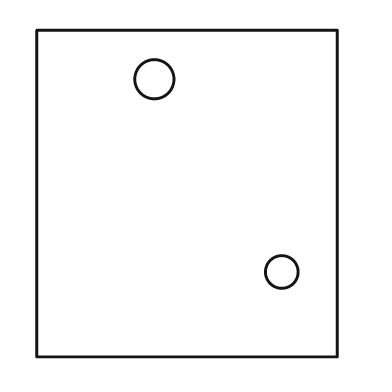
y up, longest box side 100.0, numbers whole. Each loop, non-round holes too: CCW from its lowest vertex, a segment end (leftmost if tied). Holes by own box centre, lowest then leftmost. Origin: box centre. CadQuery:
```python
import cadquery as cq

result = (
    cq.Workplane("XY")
    .moveTo(-46.0, -50.0)
    .lineTo(46.0, -50.0)
    .lineTo(46.0, 50.0)
    .lineTo(-46.0, 50.0)
    .close()
    .moveTo(29.0, -24.0)
    .circle(5.0)
    .moveTo(-10.0, 35.0)
    .circle(6.0)
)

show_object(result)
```